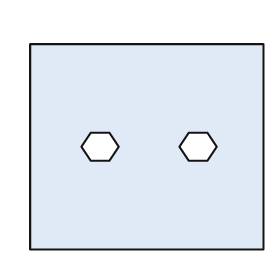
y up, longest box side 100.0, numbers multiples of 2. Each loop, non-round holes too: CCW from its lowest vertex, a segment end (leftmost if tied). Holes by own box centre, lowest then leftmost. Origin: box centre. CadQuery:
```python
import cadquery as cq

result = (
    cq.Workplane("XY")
    .moveTo(-50.0, -44.0)
    .lineTo(50.0, -44.0)
    .lineTo(50.0, 44.0)
    .lineTo(-50.0, 44.0)
    .close()
    .moveTo(-24.0, -6.0)
    .lineTo(-16.0, -6.0)
    .lineTo(-12.0, 0.0)
    .lineTo(-16.0, 6.0)
    .lineTo(-24.0, 6.0)
    .lineTo(-28.0, 0.0)
    .close()
    .moveTo(18.0, -6.0)
    .lineTo(26.0, -6.0)
    .lineTo(30.0, 0.0)
    .lineTo(26.0, 6.0)
    .lineTo(18.0, 6.0)
    .lineTo(14.0, 0.0)
    .close()
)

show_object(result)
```